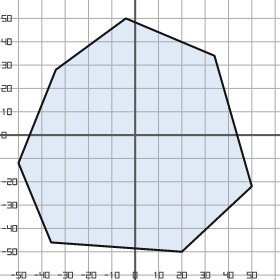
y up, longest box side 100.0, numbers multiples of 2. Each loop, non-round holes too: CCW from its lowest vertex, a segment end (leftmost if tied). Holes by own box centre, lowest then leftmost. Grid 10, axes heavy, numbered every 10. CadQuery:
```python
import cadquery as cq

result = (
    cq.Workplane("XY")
    .moveTo(20.0, -50.0)
    .lineTo(50.0, -22.0)
    .lineTo(34.0, 34.0)
    .lineTo(-4.0, 50.0)
    .lineTo(-34.0, 28.0)
    .lineTo(-50.0, -12.0)
    .lineTo(-36.0, -46.0)
    .close()
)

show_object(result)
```